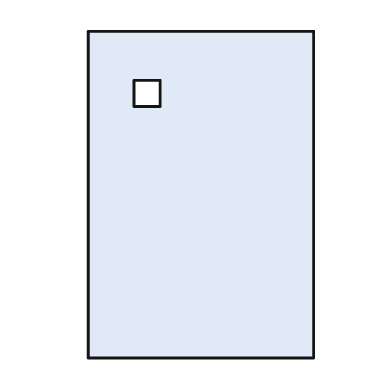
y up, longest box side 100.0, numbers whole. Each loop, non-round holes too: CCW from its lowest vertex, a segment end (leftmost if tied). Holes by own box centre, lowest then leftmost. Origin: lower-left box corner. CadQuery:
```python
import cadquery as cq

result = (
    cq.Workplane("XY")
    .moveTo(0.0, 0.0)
    .lineTo(69.0, 0.0)
    .lineTo(69.0, 100.0)
    .lineTo(0.0, 100.0)
    .close()
    .moveTo(14.0, 77.0)
    .lineTo(22.0, 77.0)
    .lineTo(22.0, 85.0)
    .lineTo(14.0, 85.0)
    .close()
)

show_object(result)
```